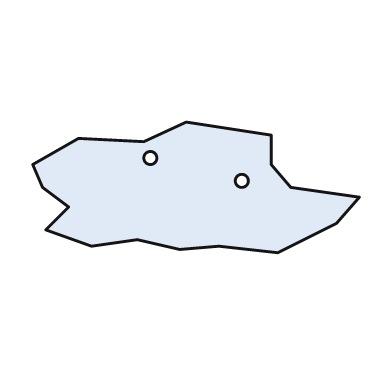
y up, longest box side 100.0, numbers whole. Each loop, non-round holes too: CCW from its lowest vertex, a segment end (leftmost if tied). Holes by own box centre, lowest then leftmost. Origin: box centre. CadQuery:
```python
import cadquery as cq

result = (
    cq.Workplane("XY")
    .moveTo(25.0, -20.0)
    .lineTo(43.0, -11.0)
    .lineTo(50.0, -3.0)
    .lineTo(29.0, 0.0)
    .lineTo(23.0, 7.0)
    .lineTo(23.0, 16.0)
    .lineTo(-3.0, 20.0)
    .lineTo(-16.0, 14.0)
    .lineTo(-36.0, 15.0)
    .lineTo(-50.0, 7.0)
    .lineTo(-47.0, 0.0)
    .lineTo(-39.0, -6.0)
    .lineTo(-46.0, -13.0)
    .lineTo(-32.0, -18.0)
    .lineTo(-18.0, -16.0)
    .lineTo(-5.0, -19.0)
    .lineTo(7.0, -18.0)
    .close()
    .moveTo(14.0, 2.0)
    .circle(2.0)
    .moveTo(-14.0, 9.0)
    .circle(2.0)
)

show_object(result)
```